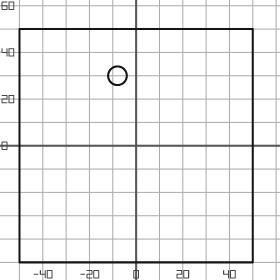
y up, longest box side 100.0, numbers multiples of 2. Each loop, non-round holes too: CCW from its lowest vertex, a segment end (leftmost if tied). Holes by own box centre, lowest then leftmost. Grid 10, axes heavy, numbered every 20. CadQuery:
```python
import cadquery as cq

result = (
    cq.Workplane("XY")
    .moveTo(-50.0, -50.0)
    .lineTo(50.0, -50.0)
    .lineTo(50.0, 50.0)
    .lineTo(-50.0, 50.0)
    .close()
    .moveTo(-8.0, 30.0)
    .circle(4.0)
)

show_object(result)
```